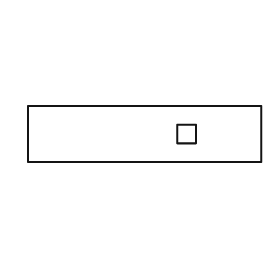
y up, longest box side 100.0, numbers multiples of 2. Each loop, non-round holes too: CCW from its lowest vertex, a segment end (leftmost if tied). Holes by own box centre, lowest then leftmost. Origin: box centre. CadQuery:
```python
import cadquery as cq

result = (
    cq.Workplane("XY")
    .moveTo(-50.0, -12.0)
    .lineTo(50.0, -12.0)
    .lineTo(50.0, 12.0)
    .lineTo(-50.0, 12.0)
    .close()
    .moveTo(14.0, -4.0)
    .lineTo(22.0, -4.0)
    .lineTo(22.0, 4.0)
    .lineTo(14.0, 4.0)
    .close()
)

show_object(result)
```